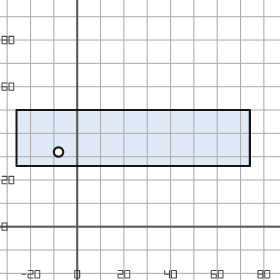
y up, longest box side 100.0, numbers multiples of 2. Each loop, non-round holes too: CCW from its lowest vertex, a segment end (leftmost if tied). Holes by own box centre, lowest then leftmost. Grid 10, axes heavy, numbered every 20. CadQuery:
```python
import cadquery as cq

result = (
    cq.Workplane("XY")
    .moveTo(-26.0, 26.0)
    .lineTo(74.0, 26.0)
    .lineTo(74.0, 50.0)
    .lineTo(-26.0, 50.0)
    .close()
    .moveTo(-8.0, 32.0)
    .circle(2.0)
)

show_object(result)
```